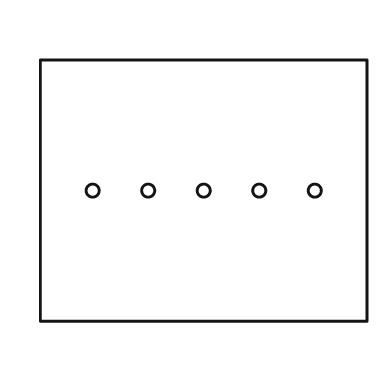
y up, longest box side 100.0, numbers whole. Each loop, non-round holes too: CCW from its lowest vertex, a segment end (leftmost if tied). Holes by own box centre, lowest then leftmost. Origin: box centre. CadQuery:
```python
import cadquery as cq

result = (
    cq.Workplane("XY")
    .moveTo(-50.0, -40.0)
    .lineTo(50.0, -40.0)
    .lineTo(50.0, 40.0)
    .lineTo(-50.0, 40.0)
    .close()
    .moveTo(-34.0, 0.0)
    .circle(2.0)
    .moveTo(-17.0, 0.0)
    .circle(2.0)
    .moveTo(0.0, 0.0)
    .circle(2.0)
    .moveTo(17.0, 0.0)
    .circle(2.0)
    .moveTo(34.0, 0.0)
    .circle(2.0)
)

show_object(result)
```